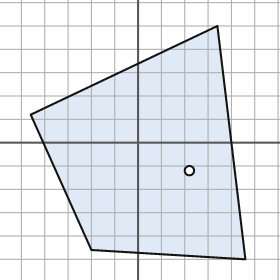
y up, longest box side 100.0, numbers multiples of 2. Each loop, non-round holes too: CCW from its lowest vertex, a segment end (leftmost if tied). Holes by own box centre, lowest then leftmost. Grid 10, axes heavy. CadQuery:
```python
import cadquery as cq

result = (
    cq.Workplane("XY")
    .moveTo(46.0, -50.0)
    .lineTo(34.0, 50.0)
    .lineTo(-46.0, 12.0)
    .lineTo(-20.0, -46.0)
    .close()
    .moveTo(22.0, -12.0)
    .circle(2.0)
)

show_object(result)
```